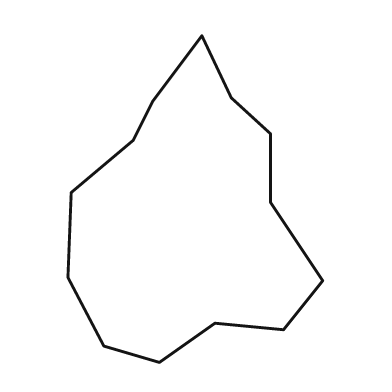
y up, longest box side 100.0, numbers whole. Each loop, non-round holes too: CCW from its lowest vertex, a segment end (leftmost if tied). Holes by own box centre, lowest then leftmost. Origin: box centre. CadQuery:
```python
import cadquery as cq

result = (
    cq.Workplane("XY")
    .moveTo(-11.0, -50.0)
    .lineTo(6.0, -38.0)
    .lineTo(27.0, -40.0)
    .lineTo(39.0, -25.0)
    .lineTo(23.0, -1.0)
    .lineTo(23.0, 20.0)
    .lineTo(11.0, 31.0)
    .lineTo(2.0, 50.0)
    .lineTo(-13.0, 30.0)
    .lineTo(-19.0, 18.0)
    .lineTo(-38.0, 2.0)
    .lineTo(-39.0, -24.0)
    .lineTo(-28.0, -45.0)
    .close()
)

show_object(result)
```